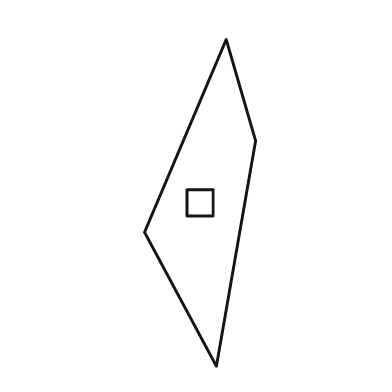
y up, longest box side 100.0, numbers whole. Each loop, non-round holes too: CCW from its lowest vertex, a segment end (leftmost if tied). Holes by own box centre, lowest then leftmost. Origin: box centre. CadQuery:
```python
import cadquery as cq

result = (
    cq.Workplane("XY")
    .moveTo(5.0, -50.0)
    .lineTo(17.0, 19.0)
    .lineTo(8.0, 50.0)
    .lineTo(-17.0, -9.0)
    .close()
    .moveTo(-4.0, -4.0)
    .lineTo(4.0, -4.0)
    .lineTo(4.0, 4.0)
    .lineTo(-4.0, 4.0)
    .close()
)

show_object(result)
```